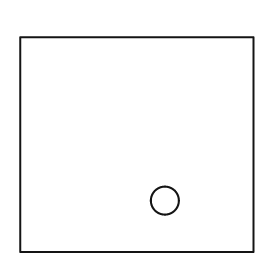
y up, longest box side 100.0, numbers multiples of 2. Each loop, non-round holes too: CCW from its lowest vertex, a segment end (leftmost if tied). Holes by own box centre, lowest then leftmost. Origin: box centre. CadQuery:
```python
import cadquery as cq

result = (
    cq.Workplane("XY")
    .moveTo(-50.0, -46.0)
    .lineTo(50.0, -46.0)
    .lineTo(50.0, 46.0)
    .lineTo(-50.0, 46.0)
    .close()
    .moveTo(12.0, -24.0)
    .circle(6.0)
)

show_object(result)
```